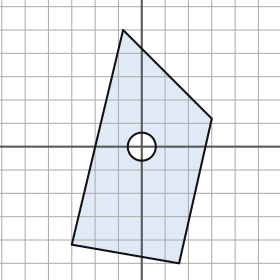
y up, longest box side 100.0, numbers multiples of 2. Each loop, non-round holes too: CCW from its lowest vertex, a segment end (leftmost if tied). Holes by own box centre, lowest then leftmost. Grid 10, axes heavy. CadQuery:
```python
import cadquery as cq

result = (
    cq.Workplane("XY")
    .moveTo(16.0, -50.0)
    .lineTo(30.0, 12.0)
    .lineTo(-8.0, 50.0)
    .lineTo(-30.0, -42.0)
    .close()
    .moveTo(0.0, 0.0)
    .circle(6.0)
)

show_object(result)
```